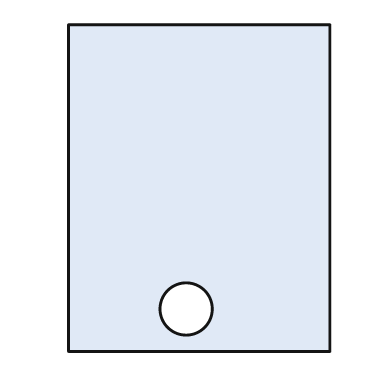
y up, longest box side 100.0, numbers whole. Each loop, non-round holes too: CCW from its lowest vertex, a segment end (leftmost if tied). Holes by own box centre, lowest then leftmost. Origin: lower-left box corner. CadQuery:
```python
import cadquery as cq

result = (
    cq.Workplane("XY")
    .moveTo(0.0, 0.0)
    .lineTo(80.0, 0.0)
    .lineTo(80.0, 100.0)
    .lineTo(0.0, 100.0)
    .close()
    .moveTo(36.0, 13.0)
    .circle(8.0)
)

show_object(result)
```